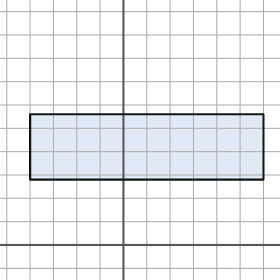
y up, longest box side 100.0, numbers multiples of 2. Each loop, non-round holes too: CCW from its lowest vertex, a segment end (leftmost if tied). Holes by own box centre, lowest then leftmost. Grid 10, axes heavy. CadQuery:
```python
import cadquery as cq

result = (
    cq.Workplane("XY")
    .moveTo(-40.0, 28.0)
    .lineTo(60.0, 28.0)
    .lineTo(60.0, 56.0)
    .lineTo(-40.0, 56.0)
    .close()
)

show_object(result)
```